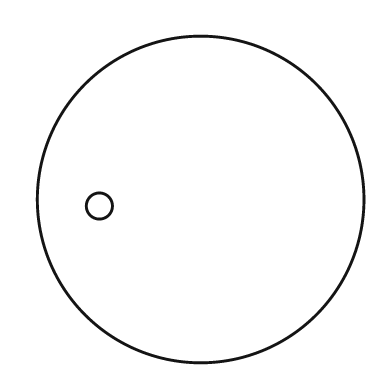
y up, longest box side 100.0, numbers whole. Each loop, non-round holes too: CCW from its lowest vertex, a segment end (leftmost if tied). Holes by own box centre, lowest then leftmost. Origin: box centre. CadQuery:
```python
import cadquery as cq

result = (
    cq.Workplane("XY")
    .moveTo(0.0, 0.0)
    .circle(50.0)
    .moveTo(-31.0, -2.0)
    .circle(4.0)
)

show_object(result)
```